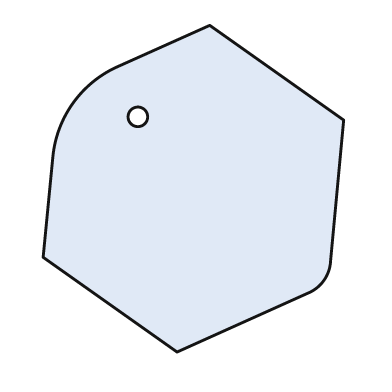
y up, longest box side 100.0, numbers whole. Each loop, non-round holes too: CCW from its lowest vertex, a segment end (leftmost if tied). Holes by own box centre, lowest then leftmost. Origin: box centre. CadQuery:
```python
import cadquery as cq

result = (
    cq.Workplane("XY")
    .moveTo(-5.0, -50.0)
    .lineTo(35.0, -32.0)
    .threePointArc((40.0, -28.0), (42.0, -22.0))
    .lineTo(46.0, 21.0)
    .lineTo(5.0, 50.0)
    .lineTo(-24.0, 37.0)
    .threePointArc((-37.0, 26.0), (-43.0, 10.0))
    .lineTo(-46.0, -21.0)
    .close()
    .moveTo(-17.0, 22.0)
    .circle(3.0)
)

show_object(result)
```